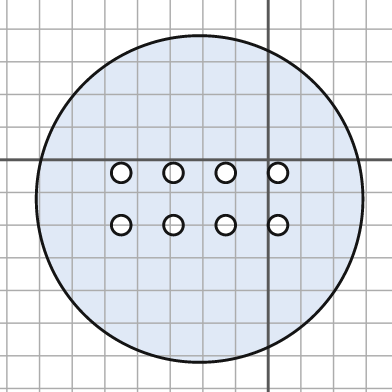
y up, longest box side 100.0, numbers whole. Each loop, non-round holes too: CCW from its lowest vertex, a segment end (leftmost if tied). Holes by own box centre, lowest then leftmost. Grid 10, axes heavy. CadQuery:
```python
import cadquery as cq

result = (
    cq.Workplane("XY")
    .moveTo(-21.0, -12.0)
    .circle(50.0)
    .moveTo(-45.0, -20.0)
    .circle(3.0)
    .moveTo(-29.0, -20.0)
    .circle(3.0)
    .moveTo(-13.0, -20.0)
    .circle(3.0)
    .moveTo(3.0, -20.0)
    .circle(3.0)
    .moveTo(-45.0, -4.0)
    .circle(3.0)
    .moveTo(-29.0, -4.0)
    .circle(3.0)
    .moveTo(-13.0, -4.0)
    .circle(3.0)
    .moveTo(3.0, -4.0)
    .circle(3.0)
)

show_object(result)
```